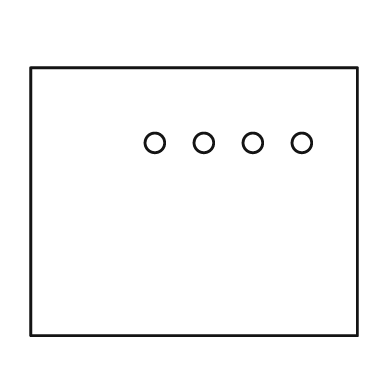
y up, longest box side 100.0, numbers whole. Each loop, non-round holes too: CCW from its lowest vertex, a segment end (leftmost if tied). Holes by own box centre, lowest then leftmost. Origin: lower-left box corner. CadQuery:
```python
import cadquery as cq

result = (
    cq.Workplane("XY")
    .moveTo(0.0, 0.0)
    .lineTo(100.0, 0.0)
    .lineTo(100.0, 82.0)
    .lineTo(0.0, 82.0)
    .close()
    .moveTo(38.0, 59.0)
    .circle(3.0)
    .moveTo(53.0, 59.0)
    .circle(3.0)
    .moveTo(68.0, 59.0)
    .circle(3.0)
    .moveTo(83.0, 59.0)
    .circle(3.0)
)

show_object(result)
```